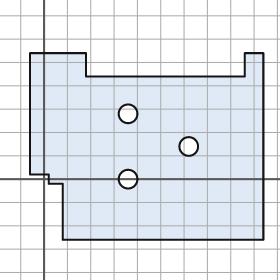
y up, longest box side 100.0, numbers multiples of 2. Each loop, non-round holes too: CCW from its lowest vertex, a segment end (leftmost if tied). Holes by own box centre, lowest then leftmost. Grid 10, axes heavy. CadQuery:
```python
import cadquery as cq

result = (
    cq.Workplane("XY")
    .moveTo(8.0, -26.0)
    .lineTo(94.0, -26.0)
    .lineTo(94.0, 54.0)
    .lineTo(86.0, 54.0)
    .lineTo(86.0, 44.0)
    .lineTo(18.0, 44.0)
    .lineTo(18.0, 54.0)
    .lineTo(-6.0, 54.0)
    .lineTo(-6.0, 2.0)
    .lineTo(2.0, 2.0)
    .lineTo(2.0, -2.0)
    .lineTo(8.0, -2.0)
    .close()
    .moveTo(36.0, 0.0)
    .circle(4.0)
    .moveTo(62.0, 14.0)
    .circle(4.0)
    .moveTo(36.0, 28.0)
    .circle(4.0)
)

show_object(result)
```